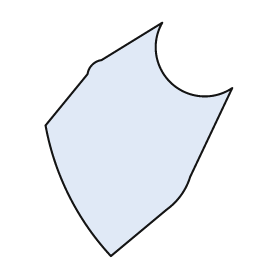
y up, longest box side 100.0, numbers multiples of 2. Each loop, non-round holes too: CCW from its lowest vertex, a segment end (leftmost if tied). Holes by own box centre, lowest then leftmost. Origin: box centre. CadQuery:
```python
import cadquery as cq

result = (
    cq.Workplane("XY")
    .moveTo(-12.0, -50.0)
    .lineTo(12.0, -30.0)
    .threePointArc((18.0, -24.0), (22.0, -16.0))
    .lineTo(40.0, 22.0)
    .threePointArc((14.0, 24.0), (10.0, 50.0))
    .lineTo(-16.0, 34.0)
    .threePointArc((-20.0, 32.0), (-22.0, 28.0))
    .lineTo(-40.0, 6.0)
    .threePointArc((-30.0, -24.0), (-12.0, -50.0))
    .close()
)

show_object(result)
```